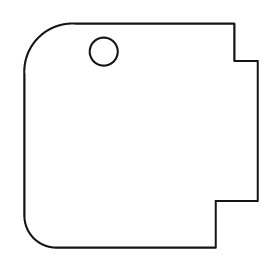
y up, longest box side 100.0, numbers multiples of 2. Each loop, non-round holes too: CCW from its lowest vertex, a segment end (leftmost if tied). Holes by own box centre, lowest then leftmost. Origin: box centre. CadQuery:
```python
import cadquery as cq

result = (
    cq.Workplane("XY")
    .moveTo(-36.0, -48.0)
    .lineTo(32.0, -48.0)
    .lineTo(32.0, -28.0)
    .lineTo(50.0, -28.0)
    .lineTo(50.0, 32.0)
    .lineTo(40.0, 32.0)
    .lineTo(40.0, 48.0)
    .lineTo(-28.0, 48.0)
    .threePointArc((-44.0, 42.0), (-50.0, 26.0))
    .lineTo(-50.0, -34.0)
    .threePointArc((-46.0, -44.0), (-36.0, -48.0))
    .close()
    .moveTo(-16.0, 36.0)
    .circle(6.0)
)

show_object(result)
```